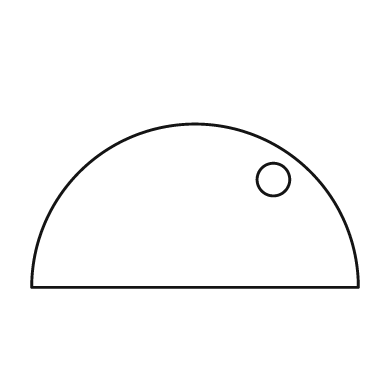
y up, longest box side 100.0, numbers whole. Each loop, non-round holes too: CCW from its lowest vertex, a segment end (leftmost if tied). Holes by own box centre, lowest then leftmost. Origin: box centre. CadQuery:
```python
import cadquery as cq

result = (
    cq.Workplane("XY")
    .moveTo(-50.0, -25.0)
    .lineTo(50.0, -25.0)
    .threePointArc((0.0, 25.0), (-50.0, -25.0))
    .close()
    .moveTo(24.0, 8.0)
    .circle(5.0)
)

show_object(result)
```